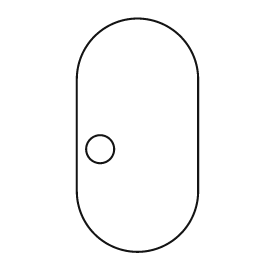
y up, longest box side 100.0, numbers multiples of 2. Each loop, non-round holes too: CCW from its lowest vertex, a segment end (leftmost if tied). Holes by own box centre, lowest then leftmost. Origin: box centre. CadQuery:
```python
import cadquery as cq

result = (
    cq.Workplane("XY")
    .moveTo(-26.0, -24.0)
    .threePointArc((0.0, -50.0), (26.0, -24.0))
    .lineTo(26.0, 24.0)
    .threePointArc((0.0, 50.0), (-26.0, 24.0))
    .close()
    .moveTo(-16.0, -6.0)
    .circle(6.0)
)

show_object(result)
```